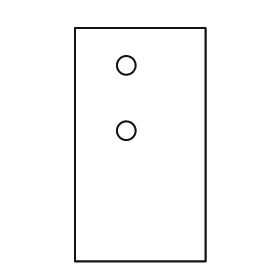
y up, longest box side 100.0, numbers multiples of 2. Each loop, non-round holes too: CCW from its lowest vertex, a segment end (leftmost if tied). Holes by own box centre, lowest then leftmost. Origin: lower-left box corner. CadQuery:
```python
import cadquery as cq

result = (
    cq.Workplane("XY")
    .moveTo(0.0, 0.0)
    .lineTo(56.0, 0.0)
    .lineTo(56.0, 100.0)
    .lineTo(0.0, 100.0)
    .close()
    .moveTo(22.0, 56.0)
    .circle(4.0)
    .moveTo(22.0, 84.0)
    .circle(4.0)
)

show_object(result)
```